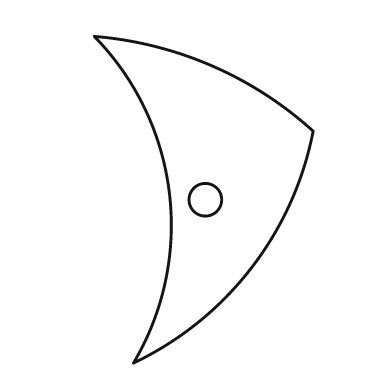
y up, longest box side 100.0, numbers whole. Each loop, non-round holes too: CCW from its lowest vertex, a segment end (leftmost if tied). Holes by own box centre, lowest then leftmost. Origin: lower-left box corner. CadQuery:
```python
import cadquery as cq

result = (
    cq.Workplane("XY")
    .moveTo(12.0, 0.0)
    .threePointArc((48.0, 29.0), (67.0, 71.0))
    .threePointArc((36.0, 91.0), (0.0, 100.0))
    .threePointArc((23.0, 52.0), (12.0, 0.0))
    .close()
    .moveTo(34.0, 50.0)
    .circle(5.0)
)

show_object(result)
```